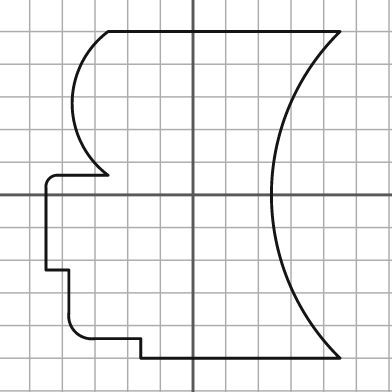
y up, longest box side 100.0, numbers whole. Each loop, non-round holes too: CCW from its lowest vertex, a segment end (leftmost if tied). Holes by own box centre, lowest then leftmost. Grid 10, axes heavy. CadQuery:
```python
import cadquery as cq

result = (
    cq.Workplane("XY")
    .moveTo(-16.0, -50.0)
    .lineTo(45.0, -50.0)
    .threePointArc((24.0, 0.0), (45.0, 50.0))
    .lineTo(-26.0, 50.0)
    .threePointArc((-37.0, 28.0), (-26.0, 6.0))
    .lineTo(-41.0, 6.0)
    .threePointArc((-44.0, 5.0), (-45.0, 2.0))
    .lineTo(-45.0, -23.0)
    .lineTo(-38.0, -23.0)
    .lineTo(-38.0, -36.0)
    .threePointArc((-36.0, -42.0), (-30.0, -44.0))
    .lineTo(-16.0, -44.0)
    .close()
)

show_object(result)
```